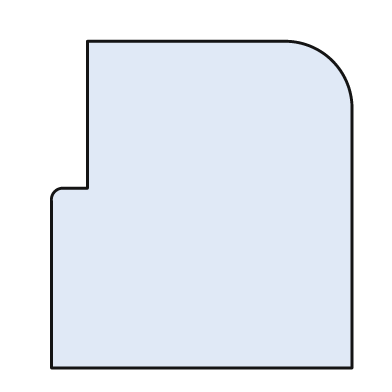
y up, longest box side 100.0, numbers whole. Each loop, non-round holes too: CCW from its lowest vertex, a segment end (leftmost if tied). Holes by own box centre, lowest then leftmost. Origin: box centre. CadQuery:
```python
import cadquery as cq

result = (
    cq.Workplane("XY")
    .moveTo(-46.0, -50.0)
    .lineTo(46.0, -50.0)
    .lineTo(46.0, 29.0)
    .threePointArc((40.0, 44.0), (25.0, 50.0))
    .lineTo(-35.0, 50.0)
    .lineTo(-35.0, 5.0)
    .lineTo(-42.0, 5.0)
    .threePointArc((-45.0, 4.0), (-46.0, 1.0))
    .close()
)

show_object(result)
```